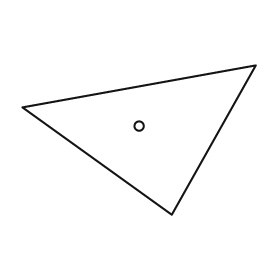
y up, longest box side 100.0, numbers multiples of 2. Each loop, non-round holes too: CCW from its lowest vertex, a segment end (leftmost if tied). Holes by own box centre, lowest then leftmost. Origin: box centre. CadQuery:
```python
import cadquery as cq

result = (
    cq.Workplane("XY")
    .moveTo(14.0, -32.0)
    .lineTo(50.0, 32.0)
    .lineTo(-50.0, 14.0)
    .close()
    .moveTo(0.0, 6.0)
    .circle(2.0)
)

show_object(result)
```